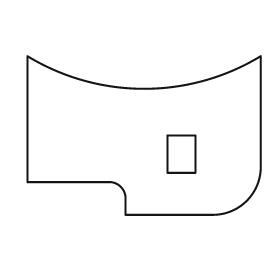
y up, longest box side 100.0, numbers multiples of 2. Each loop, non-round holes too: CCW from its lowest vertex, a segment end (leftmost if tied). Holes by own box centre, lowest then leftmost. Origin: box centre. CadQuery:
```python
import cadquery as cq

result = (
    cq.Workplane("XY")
    .moveTo(-8.0, -34.0)
    .lineTo(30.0, -34.0)
    .threePointArc((44.0, -28.0), (50.0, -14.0))
    .lineTo(50.0, 34.0)
    .threePointArc((0.0, 20.0), (-50.0, 34.0))
    .lineTo(-50.0, -20.0)
    .lineTo(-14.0, -20.0)
    .threePointArc((-10.0, -22.0), (-8.0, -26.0))
    .close()
    .moveTo(10.0, -16.0)
    .lineTo(22.0, -16.0)
    .lineTo(22.0, 0.0)
    .lineTo(10.0, 0.0)
    .close()
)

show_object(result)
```